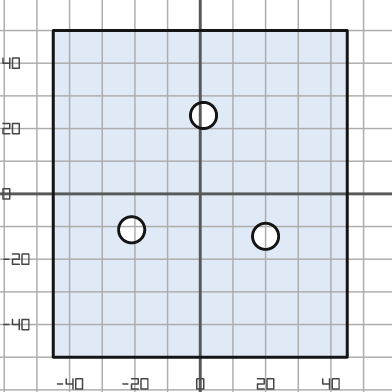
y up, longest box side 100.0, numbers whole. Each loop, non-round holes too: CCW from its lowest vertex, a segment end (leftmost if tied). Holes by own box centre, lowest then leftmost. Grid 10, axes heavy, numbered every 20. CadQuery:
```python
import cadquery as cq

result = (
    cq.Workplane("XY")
    .moveTo(-45.0, -50.0)
    .lineTo(45.0, -50.0)
    .lineTo(45.0, 50.0)
    .lineTo(-45.0, 50.0)
    .close()
    .moveTo(20.0, -13.0)
    .circle(4.0)
    .moveTo(-21.0, -11.0)
    .circle(4.0)
    .moveTo(1.0, 24.0)
    .circle(4.0)
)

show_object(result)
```